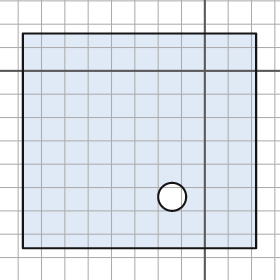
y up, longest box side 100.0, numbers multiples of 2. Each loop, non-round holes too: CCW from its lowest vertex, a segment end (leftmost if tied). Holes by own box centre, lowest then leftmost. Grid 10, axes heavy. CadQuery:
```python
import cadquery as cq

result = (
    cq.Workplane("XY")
    .moveTo(-78.0, -76.0)
    .lineTo(22.0, -76.0)
    .lineTo(22.0, 16.0)
    .lineTo(-78.0, 16.0)
    .close()
    .moveTo(-14.0, -54.0)
    .circle(6.0)
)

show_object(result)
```